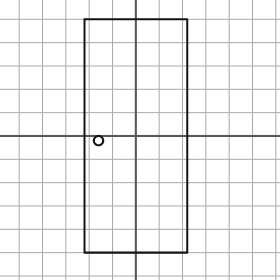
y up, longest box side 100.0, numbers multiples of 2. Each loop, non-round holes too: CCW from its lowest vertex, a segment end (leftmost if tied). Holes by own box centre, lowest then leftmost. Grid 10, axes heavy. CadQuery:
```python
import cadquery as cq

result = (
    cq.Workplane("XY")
    .moveTo(-22.0, -50.0)
    .lineTo(22.0, -50.0)
    .lineTo(22.0, 50.0)
    .lineTo(-22.0, 50.0)
    .close()
    .moveTo(-16.0, -2.0)
    .circle(2.0)
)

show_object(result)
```